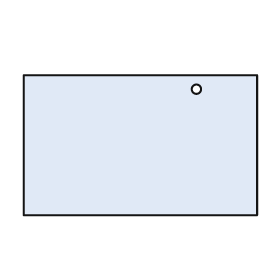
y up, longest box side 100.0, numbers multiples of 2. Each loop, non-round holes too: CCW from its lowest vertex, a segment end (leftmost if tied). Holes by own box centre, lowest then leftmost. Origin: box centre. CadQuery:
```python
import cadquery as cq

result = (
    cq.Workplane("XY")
    .moveTo(-50.0, -30.0)
    .lineTo(50.0, -30.0)
    .lineTo(50.0, 30.0)
    .lineTo(-50.0, 30.0)
    .close()
    .moveTo(24.0, 24.0)
    .circle(2.0)
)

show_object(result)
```